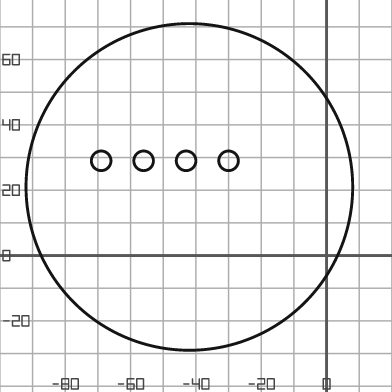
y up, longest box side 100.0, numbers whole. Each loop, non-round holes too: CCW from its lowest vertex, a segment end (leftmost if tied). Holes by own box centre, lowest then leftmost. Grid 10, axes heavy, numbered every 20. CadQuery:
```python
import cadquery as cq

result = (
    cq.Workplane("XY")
    .moveTo(-42.0, 21.0)
    .circle(50.0)
    .moveTo(-69.0, 29.0)
    .circle(3.0)
    .moveTo(-56.0, 29.0)
    .circle(3.0)
    .moveTo(-43.0, 29.0)
    .circle(3.0)
    .moveTo(-30.0, 29.0)
    .circle(3.0)
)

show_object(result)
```